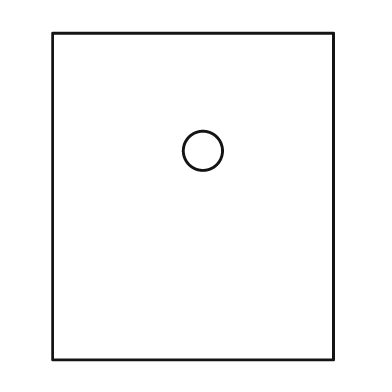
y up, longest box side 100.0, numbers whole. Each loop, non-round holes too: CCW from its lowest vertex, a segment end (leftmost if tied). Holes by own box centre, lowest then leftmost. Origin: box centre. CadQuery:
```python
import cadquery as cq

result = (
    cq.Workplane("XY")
    .moveTo(-43.0, -50.0)
    .lineTo(43.0, -50.0)
    .lineTo(43.0, 50.0)
    .lineTo(-43.0, 50.0)
    .close()
    .moveTo(3.0, 14.0)
    .circle(6.0)
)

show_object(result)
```